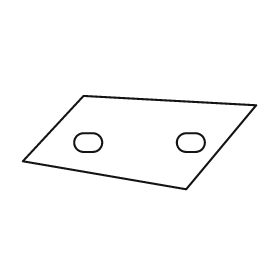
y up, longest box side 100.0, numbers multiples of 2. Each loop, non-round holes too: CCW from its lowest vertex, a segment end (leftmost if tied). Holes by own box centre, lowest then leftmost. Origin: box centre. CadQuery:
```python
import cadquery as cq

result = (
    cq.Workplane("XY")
    .moveTo(20.0, -20.0)
    .lineTo(50.0, 16.0)
    .lineTo(-24.0, 20.0)
    .lineTo(-50.0, -8.0)
    .close()
    .moveTo(-24.0, -4.0)
    .lineTo(-20.0, -4.0)
    .threePointArc((-16.0, 0.0), (-20.0, 4.0))
    .lineTo(-24.0, 4.0)
    .threePointArc((-28.0, 0.0), (-24.0, -4.0))
    .close()
    .moveTo(20.0, -4.0)
    .lineTo(24.0, -4.0)
    .threePointArc((28.0, 0.0), (24.0, 4.0))
    .lineTo(20.0, 4.0)
    .threePointArc((16.0, 0.0), (20.0, -4.0))
    .close()
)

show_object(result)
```